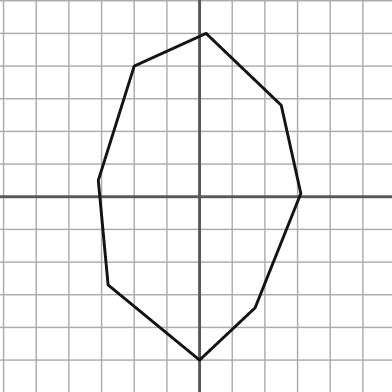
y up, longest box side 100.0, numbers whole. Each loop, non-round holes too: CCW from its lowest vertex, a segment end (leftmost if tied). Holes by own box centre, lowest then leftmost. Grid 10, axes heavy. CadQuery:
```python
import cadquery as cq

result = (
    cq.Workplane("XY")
    .moveTo(0.0, -50.0)
    .lineTo(17.0, -34.0)
    .lineTo(31.0, 1.0)
    .lineTo(25.0, 28.0)
    .lineTo(2.0, 50.0)
    .lineTo(-20.0, 40.0)
    .lineTo(-31.0, 5.0)
    .lineTo(-28.0, -27.0)
    .close()
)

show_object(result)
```